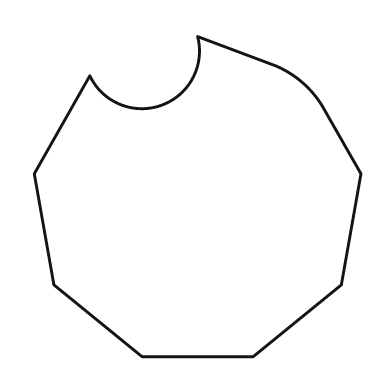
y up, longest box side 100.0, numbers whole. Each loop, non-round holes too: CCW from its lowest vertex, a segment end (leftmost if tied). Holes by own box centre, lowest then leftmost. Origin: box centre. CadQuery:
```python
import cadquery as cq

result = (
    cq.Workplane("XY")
    .moveTo(-17.0, -49.0)
    .lineTo(17.0, -49.0)
    .lineTo(44.0, -27.0)
    .lineTo(50.0, 7.0)
    .lineTo(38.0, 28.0)
    .threePointArc((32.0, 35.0), (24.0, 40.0))
    .lineTo(0.0, 49.0)
    .threePointArc((-11.0, 28.0), (-33.0, 37.0))
    .lineTo(-50.0, 7.0)
    .lineTo(-44.0, -27.0)
    .close()
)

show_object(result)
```